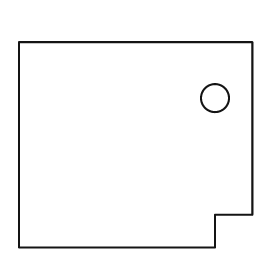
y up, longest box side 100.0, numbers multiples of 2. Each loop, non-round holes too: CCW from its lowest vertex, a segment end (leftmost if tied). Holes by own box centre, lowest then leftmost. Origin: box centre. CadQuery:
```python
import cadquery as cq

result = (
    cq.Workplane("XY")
    .moveTo(-50.0, -44.0)
    .lineTo(34.0, -44.0)
    .lineTo(34.0, -30.0)
    .lineTo(50.0, -30.0)
    .lineTo(50.0, 44.0)
    .lineTo(-50.0, 44.0)
    .close()
    .moveTo(34.0, 20.0)
    .circle(6.0)
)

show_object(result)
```